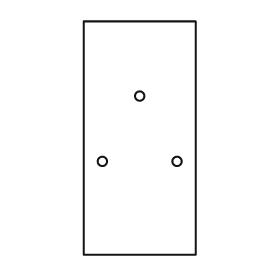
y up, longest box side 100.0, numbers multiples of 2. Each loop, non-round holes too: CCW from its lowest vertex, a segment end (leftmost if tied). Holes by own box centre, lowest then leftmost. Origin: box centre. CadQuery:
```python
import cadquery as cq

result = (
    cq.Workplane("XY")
    .moveTo(-24.0, -50.0)
    .lineTo(24.0, -50.0)
    .lineTo(24.0, 50.0)
    .lineTo(-24.0, 50.0)
    .close()
    .moveTo(-16.0, -10.0)
    .circle(2.0)
    .moveTo(16.0, -10.0)
    .circle(2.0)
    .moveTo(0.0, 18.0)
    .circle(2.0)
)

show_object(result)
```